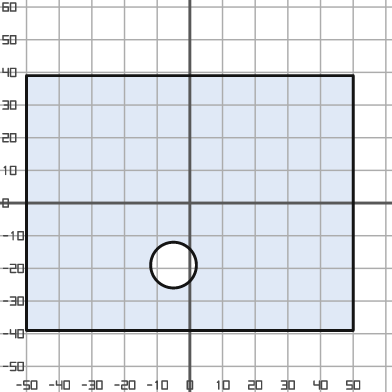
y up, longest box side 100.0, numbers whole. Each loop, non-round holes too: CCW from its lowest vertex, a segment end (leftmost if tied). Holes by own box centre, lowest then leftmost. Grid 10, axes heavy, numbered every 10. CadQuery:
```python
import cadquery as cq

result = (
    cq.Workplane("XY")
    .moveTo(-50.0, -39.0)
    .lineTo(50.0, -39.0)
    .lineTo(50.0, 39.0)
    .lineTo(-50.0, 39.0)
    .close()
    .moveTo(-5.0, -19.0)
    .circle(7.0)
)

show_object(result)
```